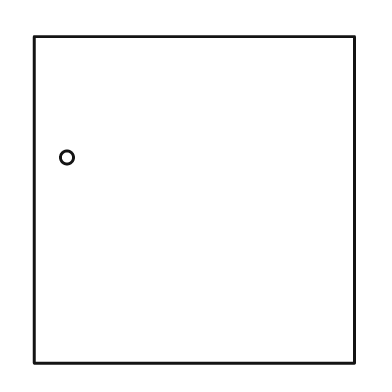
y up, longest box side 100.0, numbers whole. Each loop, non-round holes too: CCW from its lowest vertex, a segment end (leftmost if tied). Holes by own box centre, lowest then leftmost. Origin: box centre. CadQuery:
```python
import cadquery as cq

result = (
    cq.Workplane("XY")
    .moveTo(-49.0, -50.0)
    .lineTo(49.0, -50.0)
    .lineTo(49.0, 50.0)
    .lineTo(-49.0, 50.0)
    .close()
    .moveTo(-39.0, 13.0)
    .circle(2.0)
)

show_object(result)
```